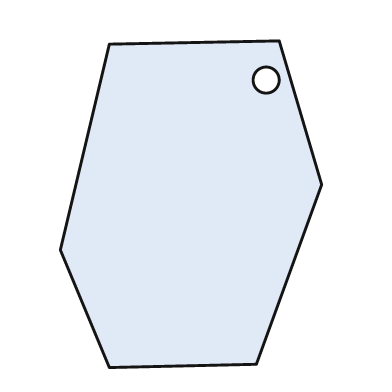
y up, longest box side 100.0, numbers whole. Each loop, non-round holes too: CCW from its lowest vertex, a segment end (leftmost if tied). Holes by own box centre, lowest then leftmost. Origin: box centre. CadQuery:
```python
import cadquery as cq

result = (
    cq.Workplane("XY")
    .moveTo(-25.0, -50.0)
    .lineTo(20.0, -49.0)
    .lineTo(40.0, 6.0)
    .lineTo(27.0, 50.0)
    .lineTo(-25.0, 49.0)
    .lineTo(-40.0, -14.0)
    .close()
    .moveTo(23.0, 38.0)
    .circle(4.0)
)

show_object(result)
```